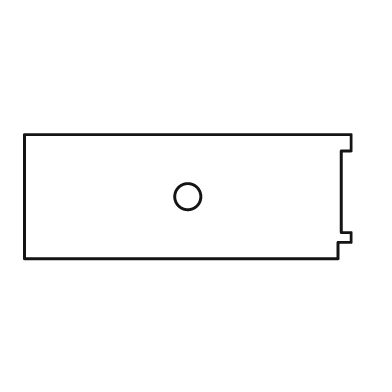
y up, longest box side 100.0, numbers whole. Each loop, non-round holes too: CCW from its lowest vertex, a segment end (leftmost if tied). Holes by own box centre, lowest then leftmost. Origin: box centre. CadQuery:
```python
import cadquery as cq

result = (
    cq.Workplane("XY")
    .moveTo(-50.0, -19.0)
    .lineTo(46.0, -19.0)
    .lineTo(46.0, -14.0)
    .lineTo(50.0, -14.0)
    .lineTo(50.0, -11.0)
    .lineTo(47.0, -11.0)
    .lineTo(47.0, 14.0)
    .lineTo(50.0, 14.0)
    .lineTo(50.0, 19.0)
    .lineTo(-50.0, 19.0)
    .close()
    .moveTo(0.0, 0.0)
    .circle(4.0)
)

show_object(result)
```